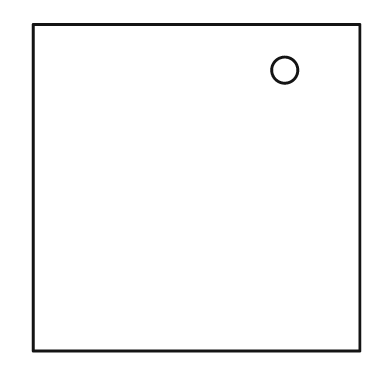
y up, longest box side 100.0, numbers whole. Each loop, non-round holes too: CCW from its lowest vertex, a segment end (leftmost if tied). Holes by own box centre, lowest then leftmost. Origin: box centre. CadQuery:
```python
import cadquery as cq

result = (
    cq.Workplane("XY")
    .moveTo(-50.0, -50.0)
    .lineTo(50.0, -50.0)
    .lineTo(50.0, 50.0)
    .lineTo(-50.0, 50.0)
    .close()
    .moveTo(27.0, 36.0)
    .circle(4.0)
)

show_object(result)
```